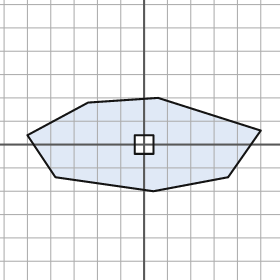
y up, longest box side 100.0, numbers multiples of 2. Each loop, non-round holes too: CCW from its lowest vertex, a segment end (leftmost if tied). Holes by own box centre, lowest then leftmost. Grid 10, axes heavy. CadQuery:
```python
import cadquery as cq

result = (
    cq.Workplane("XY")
    .moveTo(4.0, -20.0)
    .lineTo(36.0, -14.0)
    .lineTo(50.0, 6.0)
    .lineTo(6.0, 20.0)
    .lineTo(-24.0, 18.0)
    .lineTo(-50.0, 4.0)
    .lineTo(-38.0, -14.0)
    .close()
    .moveTo(-4.0, -4.0)
    .lineTo(4.0, -4.0)
    .lineTo(4.0, 4.0)
    .lineTo(-4.0, 4.0)
    .close()
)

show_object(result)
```